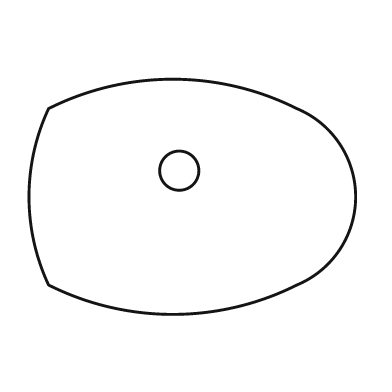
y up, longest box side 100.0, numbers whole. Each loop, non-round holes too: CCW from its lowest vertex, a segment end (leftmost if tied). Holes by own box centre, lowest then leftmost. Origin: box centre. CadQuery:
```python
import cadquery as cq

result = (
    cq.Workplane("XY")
    .moveTo(-44.0, -27.0)
    .threePointArc((-6.0, -36.0), (32.0, -27.0))
    .threePointArc((50.0, 0.0), (32.0, 27.0))
    .threePointArc((-6.0, 36.0), (-44.0, 27.0))
    .threePointArc((-50.0, 0.0), (-44.0, -27.0))
    .close()
    .moveTo(-4.0, 8.0)
    .circle(6.0)
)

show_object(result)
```